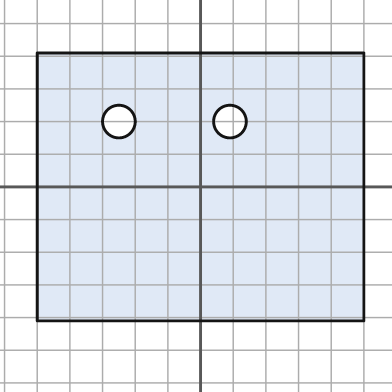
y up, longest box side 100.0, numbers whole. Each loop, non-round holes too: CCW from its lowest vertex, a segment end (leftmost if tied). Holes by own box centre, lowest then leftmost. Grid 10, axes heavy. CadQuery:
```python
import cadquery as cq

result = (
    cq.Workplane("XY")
    .moveTo(-50.0, -41.0)
    .lineTo(50.0, -41.0)
    .lineTo(50.0, 41.0)
    .lineTo(-50.0, 41.0)
    .close()
    .moveTo(-25.0, 20.0)
    .circle(5.0)
    .moveTo(9.0, 20.0)
    .circle(5.0)
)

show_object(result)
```